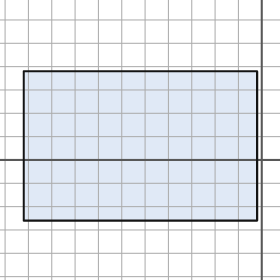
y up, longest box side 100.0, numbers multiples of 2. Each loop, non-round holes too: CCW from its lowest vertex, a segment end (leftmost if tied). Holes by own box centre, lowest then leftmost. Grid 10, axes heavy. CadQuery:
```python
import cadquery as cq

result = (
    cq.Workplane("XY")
    .moveTo(-102.0, -26.0)
    .lineTo(-2.0, -26.0)
    .lineTo(-2.0, 38.0)
    .lineTo(-102.0, 38.0)
    .close()
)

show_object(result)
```